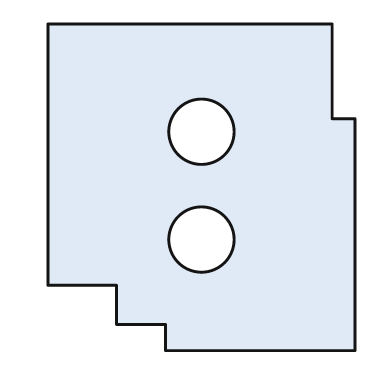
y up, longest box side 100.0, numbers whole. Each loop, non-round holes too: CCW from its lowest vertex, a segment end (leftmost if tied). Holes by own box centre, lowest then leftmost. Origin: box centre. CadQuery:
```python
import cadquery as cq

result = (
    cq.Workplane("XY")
    .moveTo(-11.0, -50.0)
    .lineTo(47.0, -50.0)
    .lineTo(47.0, 21.0)
    .lineTo(40.0, 21.0)
    .lineTo(40.0, 50.0)
    .lineTo(-47.0, 50.0)
    .lineTo(-47.0, -30.0)
    .lineTo(-26.0, -30.0)
    .lineTo(-26.0, -42.0)
    .lineTo(-11.0, -42.0)
    .close()
    .moveTo(0.0, -16.0)
    .circle(10.0)
    .moveTo(0.0, 17.0)
    .circle(10.0)
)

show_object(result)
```